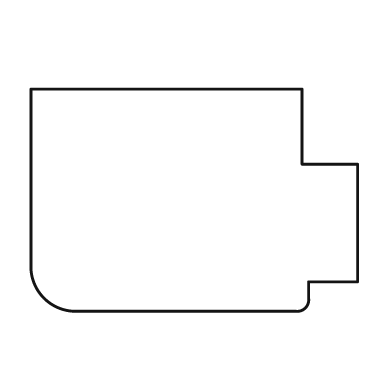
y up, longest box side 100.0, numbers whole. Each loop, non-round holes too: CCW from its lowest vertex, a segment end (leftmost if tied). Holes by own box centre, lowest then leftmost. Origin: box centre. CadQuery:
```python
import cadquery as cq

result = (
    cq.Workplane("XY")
    .moveTo(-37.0, -34.0)
    .lineTo(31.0, -34.0)
    .threePointArc((34.0, -33.0), (35.0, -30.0))
    .lineTo(35.0, -25.0)
    .lineTo(50.0, -25.0)
    .lineTo(50.0, 11.0)
    .lineTo(33.0, 11.0)
    .lineTo(33.0, 34.0)
    .lineTo(-50.0, 34.0)
    .lineTo(-50.0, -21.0)
    .threePointArc((-46.0, -30.0), (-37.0, -34.0))
    .close()
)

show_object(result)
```